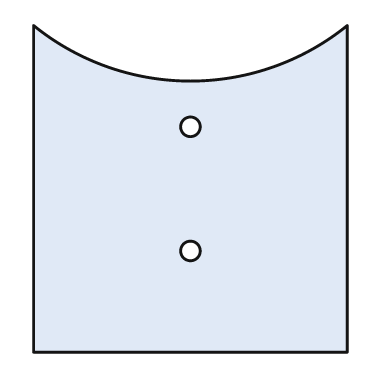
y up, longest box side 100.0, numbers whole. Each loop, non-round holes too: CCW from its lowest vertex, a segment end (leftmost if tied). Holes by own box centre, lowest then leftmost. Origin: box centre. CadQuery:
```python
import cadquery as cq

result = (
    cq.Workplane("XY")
    .moveTo(-48.0, -50.0)
    .lineTo(48.0, -50.0)
    .lineTo(48.0, 50.0)
    .threePointArc((0.0, 33.0), (-48.0, 50.0))
    .close()
    .moveTo(0.0, -19.0)
    .circle(3.0)
    .moveTo(0.0, 19.0)
    .circle(3.0)
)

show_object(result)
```